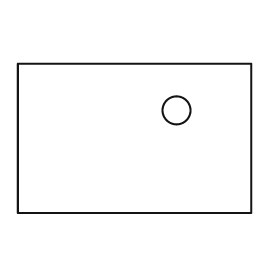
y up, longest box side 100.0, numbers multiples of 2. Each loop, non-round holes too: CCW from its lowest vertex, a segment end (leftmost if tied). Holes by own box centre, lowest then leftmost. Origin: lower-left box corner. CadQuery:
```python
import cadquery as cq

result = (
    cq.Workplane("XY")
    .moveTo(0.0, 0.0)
    .lineTo(100.0, 0.0)
    .lineTo(100.0, 64.0)
    .lineTo(0.0, 64.0)
    .close()
    .moveTo(68.0, 44.0)
    .circle(6.0)
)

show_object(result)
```